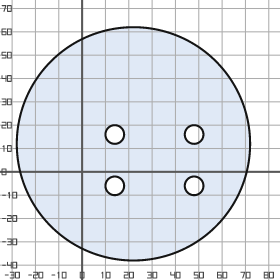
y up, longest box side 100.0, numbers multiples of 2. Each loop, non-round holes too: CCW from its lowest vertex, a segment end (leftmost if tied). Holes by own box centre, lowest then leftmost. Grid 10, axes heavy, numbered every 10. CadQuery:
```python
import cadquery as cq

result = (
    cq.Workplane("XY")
    .moveTo(22.0, 12.0)
    .circle(50.0)
    .moveTo(14.0, -6.0)
    .circle(4.0)
    .moveTo(48.0, -6.0)
    .circle(4.0)
    .moveTo(14.0, 16.0)
    .circle(4.0)
    .moveTo(48.0, 16.0)
    .circle(4.0)
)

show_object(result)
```